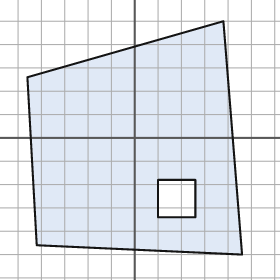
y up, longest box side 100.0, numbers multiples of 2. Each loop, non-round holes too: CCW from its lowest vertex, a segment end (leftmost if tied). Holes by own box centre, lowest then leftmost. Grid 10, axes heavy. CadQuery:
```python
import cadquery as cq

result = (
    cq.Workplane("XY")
    .moveTo(46.0, -50.0)
    .lineTo(38.0, 50.0)
    .lineTo(-46.0, 26.0)
    .lineTo(-42.0, -46.0)
    .close()
    .moveTo(10.0, -34.0)
    .lineTo(26.0, -34.0)
    .lineTo(26.0, -18.0)
    .lineTo(10.0, -18.0)
    .close()
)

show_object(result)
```